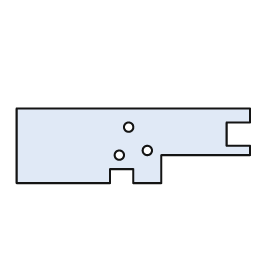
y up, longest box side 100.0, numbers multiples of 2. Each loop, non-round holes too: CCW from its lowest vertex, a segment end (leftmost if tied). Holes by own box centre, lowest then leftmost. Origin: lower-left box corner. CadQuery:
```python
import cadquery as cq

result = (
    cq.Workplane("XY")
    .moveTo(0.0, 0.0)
    .lineTo(40.0, 0.0)
    .lineTo(40.0, 6.0)
    .lineTo(50.0, 6.0)
    .lineTo(50.0, 0.0)
    .lineTo(62.0, 0.0)
    .lineTo(62.0, 12.0)
    .lineTo(100.0, 12.0)
    .lineTo(100.0, 16.0)
    .lineTo(90.0, 16.0)
    .lineTo(90.0, 26.0)
    .lineTo(100.0, 26.0)
    .lineTo(100.0, 32.0)
    .lineTo(0.0, 32.0)
    .close()
    .moveTo(44.0, 12.0)
    .circle(2.0)
    .moveTo(56.0, 14.0)
    .circle(2.0)
    .moveTo(48.0, 24.0)
    .circle(2.0)
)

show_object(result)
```